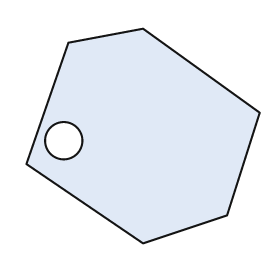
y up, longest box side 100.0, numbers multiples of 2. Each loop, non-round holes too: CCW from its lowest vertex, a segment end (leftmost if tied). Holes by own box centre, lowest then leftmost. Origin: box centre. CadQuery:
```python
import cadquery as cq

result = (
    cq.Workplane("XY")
    .moveTo(0.0, -46.0)
    .lineTo(36.0, -34.0)
    .lineTo(50.0, 10.0)
    .lineTo(0.0, 46.0)
    .lineTo(-32.0, 40.0)
    .lineTo(-50.0, -12.0)
    .close()
    .moveTo(-34.0, -2.0)
    .circle(8.0)
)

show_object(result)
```